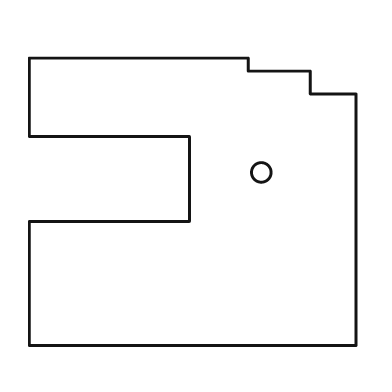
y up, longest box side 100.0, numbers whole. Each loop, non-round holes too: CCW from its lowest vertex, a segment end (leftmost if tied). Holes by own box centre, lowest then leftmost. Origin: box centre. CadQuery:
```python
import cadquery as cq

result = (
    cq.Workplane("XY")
    .moveTo(-50.0, -44.0)
    .lineTo(50.0, -44.0)
    .lineTo(50.0, 33.0)
    .lineTo(36.0, 33.0)
    .lineTo(36.0, 40.0)
    .lineTo(17.0, 40.0)
    .lineTo(17.0, 44.0)
    .lineTo(-50.0, 44.0)
    .lineTo(-50.0, 20.0)
    .lineTo(-1.0, 20.0)
    .lineTo(-1.0, -6.0)
    .lineTo(-50.0, -6.0)
    .close()
    .moveTo(21.0, 9.0)
    .circle(3.0)
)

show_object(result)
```